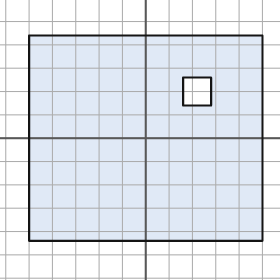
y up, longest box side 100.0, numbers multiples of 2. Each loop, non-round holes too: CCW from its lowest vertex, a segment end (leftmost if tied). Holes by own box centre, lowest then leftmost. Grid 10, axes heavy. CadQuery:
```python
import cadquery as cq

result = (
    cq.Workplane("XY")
    .moveTo(-50.0, -44.0)
    .lineTo(50.0, -44.0)
    .lineTo(50.0, 44.0)
    .lineTo(-50.0, 44.0)
    .close()
    .moveTo(16.0, 14.0)
    .lineTo(28.0, 14.0)
    .lineTo(28.0, 26.0)
    .lineTo(16.0, 26.0)
    .close()
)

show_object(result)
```